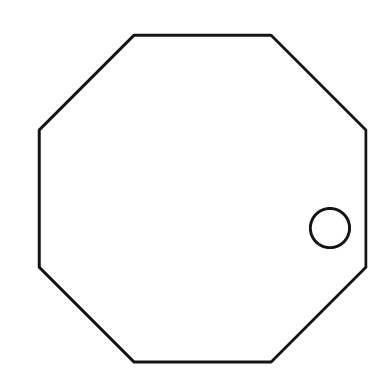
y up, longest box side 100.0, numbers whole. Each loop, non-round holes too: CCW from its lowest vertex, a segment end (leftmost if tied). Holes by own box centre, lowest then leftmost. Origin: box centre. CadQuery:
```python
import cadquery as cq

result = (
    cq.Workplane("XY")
    .moveTo(-21.0, -50.0)
    .lineTo(21.0, -50.0)
    .lineTo(50.0, -21.0)
    .lineTo(50.0, 21.0)
    .lineTo(21.0, 50.0)
    .lineTo(-21.0, 50.0)
    .lineTo(-50.0, 21.0)
    .lineTo(-50.0, -21.0)
    .close()
    .moveTo(39.0, -9.0)
    .circle(6.0)
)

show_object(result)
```